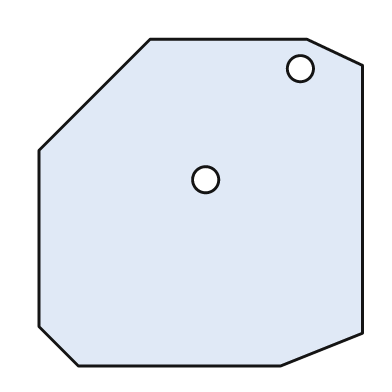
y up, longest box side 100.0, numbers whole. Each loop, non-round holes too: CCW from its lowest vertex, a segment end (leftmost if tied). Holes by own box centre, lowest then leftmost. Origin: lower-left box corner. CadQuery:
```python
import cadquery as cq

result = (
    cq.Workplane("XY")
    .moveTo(12.0, 0.0)
    .lineTo(74.0, 0.0)
    .lineTo(99.0, 10.0)
    .lineTo(99.0, 92.0)
    .lineTo(82.0, 100.0)
    .lineTo(34.0, 100.0)
    .lineTo(0.0, 66.0)
    .lineTo(0.0, 12.0)
    .close()
    .moveTo(51.0, 57.0)
    .circle(4.0)
    .moveTo(80.0, 91.0)
    .circle(4.0)
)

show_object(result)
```